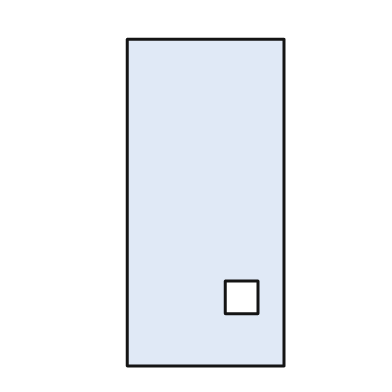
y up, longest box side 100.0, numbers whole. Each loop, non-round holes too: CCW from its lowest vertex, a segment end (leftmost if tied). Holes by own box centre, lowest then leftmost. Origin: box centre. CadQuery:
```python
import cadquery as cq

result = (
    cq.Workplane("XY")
    .moveTo(-24.0, -50.0)
    .lineTo(24.0, -50.0)
    .lineTo(24.0, 50.0)
    .lineTo(-24.0, 50.0)
    .close()
    .moveTo(6.0, -34.0)
    .lineTo(16.0, -34.0)
    .lineTo(16.0, -24.0)
    .lineTo(6.0, -24.0)
    .close()
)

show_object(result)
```